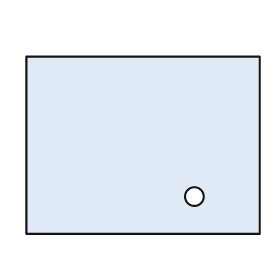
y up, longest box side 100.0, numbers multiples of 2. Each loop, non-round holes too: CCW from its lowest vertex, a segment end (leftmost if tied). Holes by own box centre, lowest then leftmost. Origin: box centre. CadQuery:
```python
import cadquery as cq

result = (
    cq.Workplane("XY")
    .moveTo(-50.0, -38.0)
    .lineTo(50.0, -38.0)
    .lineTo(50.0, 38.0)
    .lineTo(-50.0, 38.0)
    .close()
    .moveTo(22.0, -22.0)
    .circle(4.0)
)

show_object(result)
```